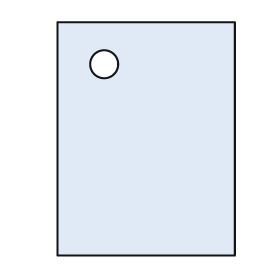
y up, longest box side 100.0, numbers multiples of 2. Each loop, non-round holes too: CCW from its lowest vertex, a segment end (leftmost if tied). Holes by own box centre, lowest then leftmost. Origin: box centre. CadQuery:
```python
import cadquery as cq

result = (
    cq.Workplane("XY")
    .moveTo(-38.0, -50.0)
    .lineTo(38.0, -50.0)
    .lineTo(38.0, 50.0)
    .lineTo(-38.0, 50.0)
    .close()
    .moveTo(-18.0, 32.0)
    .circle(6.0)
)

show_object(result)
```